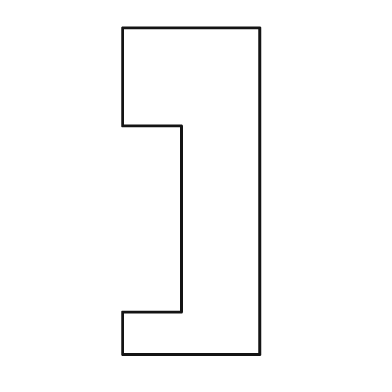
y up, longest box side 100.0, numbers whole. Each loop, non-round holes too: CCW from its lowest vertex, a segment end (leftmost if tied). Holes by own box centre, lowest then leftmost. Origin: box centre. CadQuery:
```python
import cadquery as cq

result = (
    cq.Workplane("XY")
    .moveTo(-21.0, -50.0)
    .lineTo(21.0, -50.0)
    .lineTo(21.0, 50.0)
    .lineTo(-21.0, 50.0)
    .lineTo(-21.0, 20.0)
    .lineTo(-3.0, 20.0)
    .lineTo(-3.0, -37.0)
    .lineTo(-21.0, -37.0)
    .close()
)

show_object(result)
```